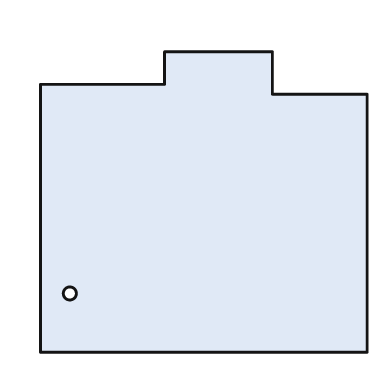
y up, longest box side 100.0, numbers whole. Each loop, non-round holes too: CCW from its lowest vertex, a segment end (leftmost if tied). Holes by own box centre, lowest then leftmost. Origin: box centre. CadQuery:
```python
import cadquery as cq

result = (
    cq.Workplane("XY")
    .moveTo(-50.0, -46.0)
    .lineTo(50.0, -46.0)
    .lineTo(50.0, 33.0)
    .lineTo(21.0, 33.0)
    .lineTo(21.0, 46.0)
    .lineTo(-12.0, 46.0)
    .lineTo(-12.0, 36.0)
    .lineTo(-50.0, 36.0)
    .close()
    .moveTo(-41.0, -28.0)
    .circle(2.0)
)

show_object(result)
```